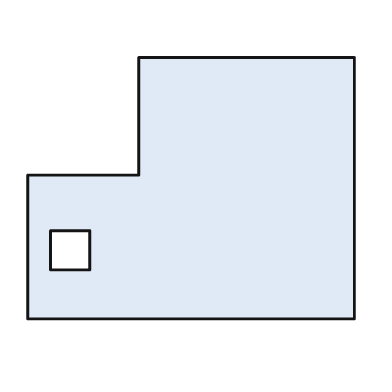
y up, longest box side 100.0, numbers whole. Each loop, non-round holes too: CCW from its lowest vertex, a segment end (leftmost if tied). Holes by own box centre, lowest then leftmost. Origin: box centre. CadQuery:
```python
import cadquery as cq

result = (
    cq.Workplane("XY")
    .moveTo(-50.0, -40.0)
    .lineTo(50.0, -40.0)
    .lineTo(50.0, 40.0)
    .lineTo(-16.0, 40.0)
    .lineTo(-16.0, 4.0)
    .lineTo(-50.0, 4.0)
    .close()
    .moveTo(-43.0, -25.0)
    .lineTo(-31.0, -25.0)
    .lineTo(-31.0, -13.0)
    .lineTo(-43.0, -13.0)
    .close()
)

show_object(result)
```